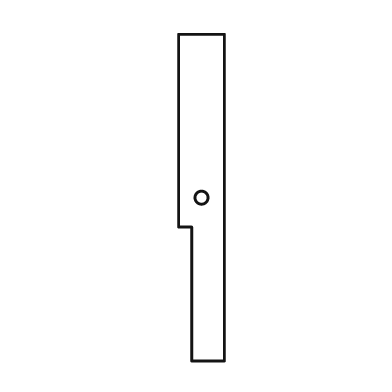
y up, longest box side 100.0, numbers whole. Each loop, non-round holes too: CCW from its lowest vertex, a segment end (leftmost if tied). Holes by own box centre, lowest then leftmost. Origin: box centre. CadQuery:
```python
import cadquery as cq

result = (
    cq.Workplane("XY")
    .moveTo(-3.0, -50.0)
    .lineTo(7.0, -50.0)
    .lineTo(7.0, 50.0)
    .lineTo(-7.0, 50.0)
    .lineTo(-7.0, -9.0)
    .lineTo(-3.0, -9.0)
    .close()
    .moveTo(0.0, 0.0)
    .circle(2.0)
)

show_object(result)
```